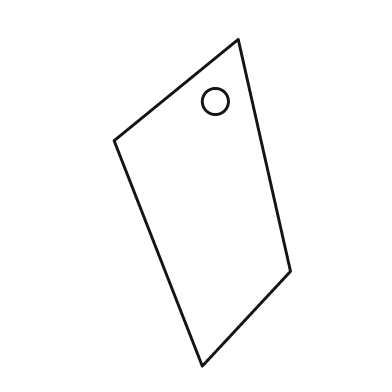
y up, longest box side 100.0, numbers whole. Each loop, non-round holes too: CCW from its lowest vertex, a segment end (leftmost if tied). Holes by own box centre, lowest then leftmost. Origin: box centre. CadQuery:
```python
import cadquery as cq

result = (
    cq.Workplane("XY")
    .moveTo(0.0, -50.0)
    .lineTo(27.0, -21.0)
    .lineTo(11.0, 50.0)
    .lineTo(-27.0, 19.0)
    .close()
    .moveTo(4.0, 31.0)
    .circle(4.0)
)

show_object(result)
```